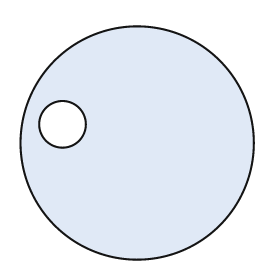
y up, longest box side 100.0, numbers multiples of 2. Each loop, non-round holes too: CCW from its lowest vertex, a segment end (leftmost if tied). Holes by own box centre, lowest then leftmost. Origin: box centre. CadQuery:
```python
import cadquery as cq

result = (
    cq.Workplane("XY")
    .moveTo(0.0, 0.0)
    .circle(50.0)
    .moveTo(-32.0, 8.0)
    .circle(10.0)
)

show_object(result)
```